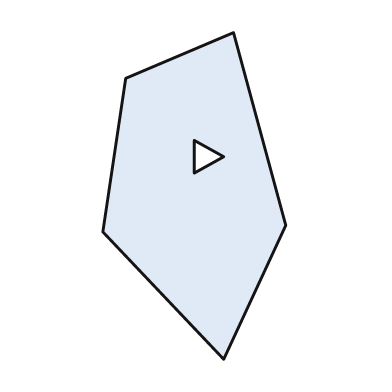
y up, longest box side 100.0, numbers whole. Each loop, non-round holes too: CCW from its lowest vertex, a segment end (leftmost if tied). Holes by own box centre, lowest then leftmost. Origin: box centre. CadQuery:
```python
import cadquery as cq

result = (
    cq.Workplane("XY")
    .moveTo(9.0, -50.0)
    .lineTo(28.0, -9.0)
    .lineTo(12.0, 50.0)
    .lineTo(-21.0, 36.0)
    .lineTo(-28.0, -11.0)
    .close()
    .moveTo(0.0, 7.0)
    .lineTo(9.0, 12.0)
    .lineTo(0.0, 17.0)
    .close()
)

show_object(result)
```